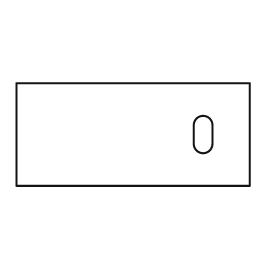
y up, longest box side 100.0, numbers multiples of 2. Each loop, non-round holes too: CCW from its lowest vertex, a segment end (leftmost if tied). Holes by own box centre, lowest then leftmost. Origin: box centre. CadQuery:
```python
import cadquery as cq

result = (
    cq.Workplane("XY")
    .moveTo(-50.0, -22.0)
    .lineTo(50.0, -22.0)
    .lineTo(50.0, 22.0)
    .lineTo(-50.0, 22.0)
    .close()
    .moveTo(26.0, -4.0)
    .threePointArc((30.0, -8.0), (34.0, -4.0))
    .lineTo(34.0, 4.0)
    .threePointArc((30.0, 8.0), (26.0, 4.0))
    .close()
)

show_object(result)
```